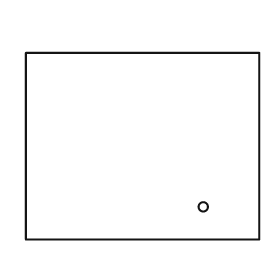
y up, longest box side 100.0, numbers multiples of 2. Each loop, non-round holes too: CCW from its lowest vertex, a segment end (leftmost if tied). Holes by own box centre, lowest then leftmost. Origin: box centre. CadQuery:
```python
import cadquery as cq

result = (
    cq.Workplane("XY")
    .moveTo(-50.0, -40.0)
    .lineTo(50.0, -40.0)
    .lineTo(50.0, 40.0)
    .lineTo(-50.0, 40.0)
    .close()
    .moveTo(26.0, -26.0)
    .circle(2.0)
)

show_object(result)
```